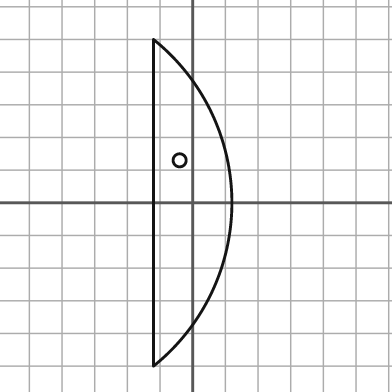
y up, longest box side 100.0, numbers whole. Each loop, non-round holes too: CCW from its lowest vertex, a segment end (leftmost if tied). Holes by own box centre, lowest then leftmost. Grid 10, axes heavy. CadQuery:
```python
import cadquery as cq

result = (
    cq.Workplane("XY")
    .moveTo(-12.0, -50.0)
    .threePointArc((12.0, 0.0), (-12.0, 50.0))
    .close()
    .moveTo(-4.0, 13.0)
    .circle(2.0)
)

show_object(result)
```